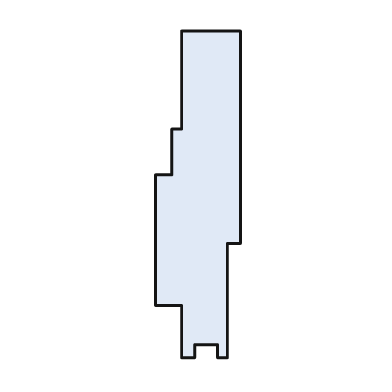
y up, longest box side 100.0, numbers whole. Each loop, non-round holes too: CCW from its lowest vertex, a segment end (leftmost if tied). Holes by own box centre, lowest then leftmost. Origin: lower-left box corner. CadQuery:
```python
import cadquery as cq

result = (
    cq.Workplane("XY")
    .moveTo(8.0, 0.0)
    .lineTo(12.0, 0.0)
    .lineTo(12.0, 4.0)
    .lineTo(19.0, 4.0)
    .lineTo(19.0, 0.0)
    .lineTo(22.0, 0.0)
    .lineTo(22.0, 35.0)
    .lineTo(26.0, 35.0)
    .lineTo(26.0, 100.0)
    .lineTo(8.0, 100.0)
    .lineTo(8.0, 70.0)
    .lineTo(5.0, 70.0)
    .lineTo(5.0, 56.0)
    .lineTo(0.0, 56.0)
    .lineTo(0.0, 16.0)
    .lineTo(8.0, 16.0)
    .close()
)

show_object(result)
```